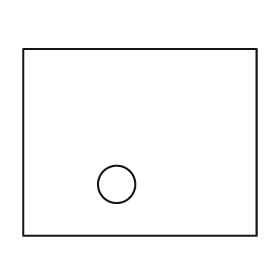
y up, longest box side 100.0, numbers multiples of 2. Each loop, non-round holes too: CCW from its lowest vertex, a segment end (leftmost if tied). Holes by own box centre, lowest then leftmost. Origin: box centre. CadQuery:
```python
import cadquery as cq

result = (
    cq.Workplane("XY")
    .moveTo(-50.0, -40.0)
    .lineTo(50.0, -40.0)
    .lineTo(50.0, 40.0)
    .lineTo(-50.0, 40.0)
    .close()
    .moveTo(-10.0, -18.0)
    .circle(8.0)
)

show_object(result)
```